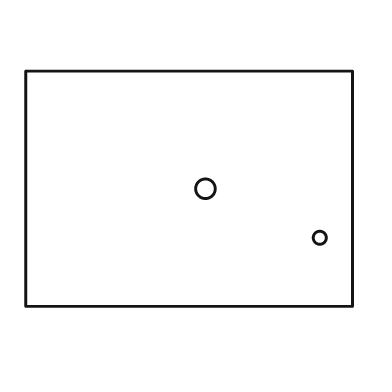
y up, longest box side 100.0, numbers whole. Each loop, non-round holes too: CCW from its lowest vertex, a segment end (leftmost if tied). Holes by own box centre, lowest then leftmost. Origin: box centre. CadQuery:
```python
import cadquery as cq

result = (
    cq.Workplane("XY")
    .moveTo(-50.0, -36.0)
    .lineTo(50.0, -36.0)
    .lineTo(50.0, 36.0)
    .lineTo(-50.0, 36.0)
    .close()
    .moveTo(40.0, -15.0)
    .circle(2.0)
    .moveTo(5.0, 0.0)
    .circle(3.0)
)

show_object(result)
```